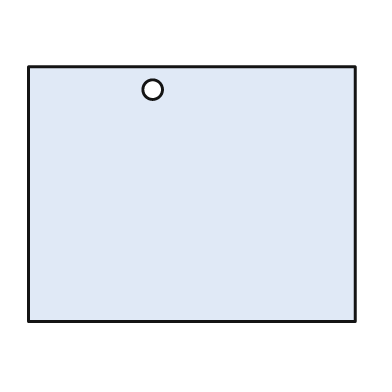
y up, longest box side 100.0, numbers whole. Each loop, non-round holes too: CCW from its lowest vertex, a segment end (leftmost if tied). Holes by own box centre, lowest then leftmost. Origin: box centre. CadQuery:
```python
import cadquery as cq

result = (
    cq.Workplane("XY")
    .moveTo(-50.0, -39.0)
    .lineTo(50.0, -39.0)
    .lineTo(50.0, 39.0)
    .lineTo(-50.0, 39.0)
    .close()
    .moveTo(-12.0, 32.0)
    .circle(3.0)
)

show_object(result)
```